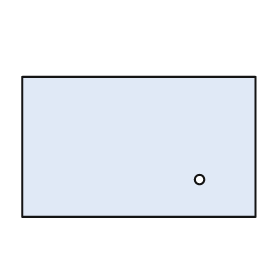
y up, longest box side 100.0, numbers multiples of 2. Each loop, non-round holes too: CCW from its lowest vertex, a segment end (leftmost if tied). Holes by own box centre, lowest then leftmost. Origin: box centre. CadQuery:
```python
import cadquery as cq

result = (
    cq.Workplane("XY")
    .moveTo(-50.0, -30.0)
    .lineTo(50.0, -30.0)
    .lineTo(50.0, 30.0)
    .lineTo(-50.0, 30.0)
    .close()
    .moveTo(26.0, -14.0)
    .circle(2.0)
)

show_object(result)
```